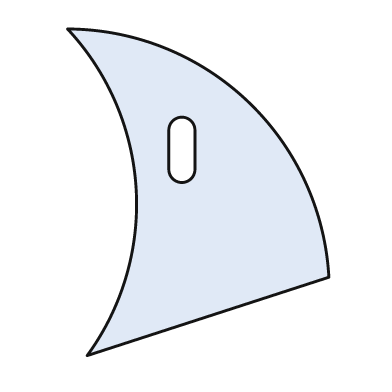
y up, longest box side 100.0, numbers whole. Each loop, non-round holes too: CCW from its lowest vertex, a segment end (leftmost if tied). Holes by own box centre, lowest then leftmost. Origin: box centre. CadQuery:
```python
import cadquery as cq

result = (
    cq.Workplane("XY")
    .moveTo(-34.0, -50.0)
    .lineTo(40.0, -26.0)
    .threePointArc((15.0, 28.0), (-40.0, 50.0))
    .threePointArc((-19.0, 1.0), (-34.0, -50.0))
    .close()
    .moveTo(-9.0, 7.0)
    .threePointArc((-5.0, 3.0), (-1.0, 7.0))
    .lineTo(-1.0, 19.0)
    .threePointArc((-5.0, 23.0), (-9.0, 19.0))
    .close()
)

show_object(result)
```